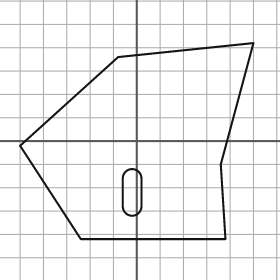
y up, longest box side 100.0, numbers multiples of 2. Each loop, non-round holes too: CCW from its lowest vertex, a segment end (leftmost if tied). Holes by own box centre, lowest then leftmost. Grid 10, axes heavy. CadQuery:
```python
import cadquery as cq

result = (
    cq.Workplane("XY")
    .moveTo(-24.0, -42.0)
    .lineTo(38.0, -42.0)
    .lineTo(36.0, -10.0)
    .lineTo(50.0, 42.0)
    .lineTo(-8.0, 36.0)
    .lineTo(-50.0, -2.0)
    .close()
    .moveTo(-6.0, -28.0)
    .threePointArc((-2.0, -32.0), (2.0, -28.0))
    .lineTo(2.0, -16.0)
    .threePointArc((-2.0, -12.0), (-6.0, -16.0))
    .close()
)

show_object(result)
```